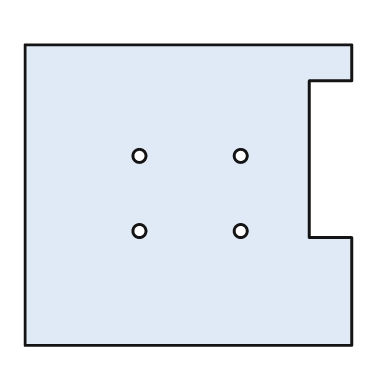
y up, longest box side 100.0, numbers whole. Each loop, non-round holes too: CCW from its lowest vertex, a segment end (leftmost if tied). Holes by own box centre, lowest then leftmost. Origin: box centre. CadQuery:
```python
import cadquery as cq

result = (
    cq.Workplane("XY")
    .moveTo(-50.0, -46.0)
    .lineTo(50.0, -46.0)
    .lineTo(50.0, -13.0)
    .lineTo(37.0, -13.0)
    .lineTo(37.0, 35.0)
    .lineTo(50.0, 35.0)
    .lineTo(50.0, 46.0)
    .lineTo(-50.0, 46.0)
    .close()
    .moveTo(-15.0, -11.0)
    .circle(2.0)
    .moveTo(16.0, -11.0)
    .circle(2.0)
    .moveTo(-15.0, 12.0)
    .circle(2.0)
    .moveTo(16.0, 12.0)
    .circle(2.0)
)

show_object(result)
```